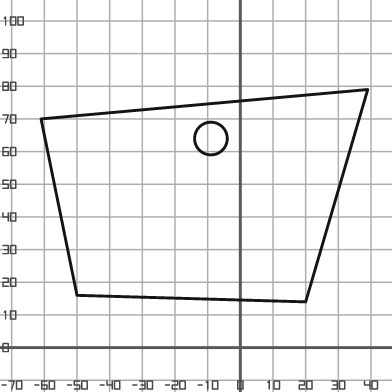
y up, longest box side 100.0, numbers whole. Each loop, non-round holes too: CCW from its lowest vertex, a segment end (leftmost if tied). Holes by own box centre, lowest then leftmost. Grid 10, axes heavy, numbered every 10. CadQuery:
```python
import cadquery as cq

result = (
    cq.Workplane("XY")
    .moveTo(20.0, 14.0)
    .lineTo(39.0, 79.0)
    .lineTo(-61.0, 70.0)
    .lineTo(-50.0, 16.0)
    .close()
    .moveTo(-9.0, 64.0)
    .circle(5.0)
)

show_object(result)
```